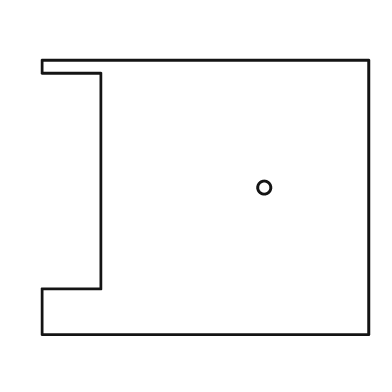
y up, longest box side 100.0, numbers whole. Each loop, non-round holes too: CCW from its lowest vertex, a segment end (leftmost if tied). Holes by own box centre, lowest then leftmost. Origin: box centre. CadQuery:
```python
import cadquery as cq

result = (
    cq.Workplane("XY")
    .moveTo(-50.0, -42.0)
    .lineTo(50.0, -42.0)
    .lineTo(50.0, 42.0)
    .lineTo(-50.0, 42.0)
    .lineTo(-50.0, 38.0)
    .lineTo(-32.0, 38.0)
    .lineTo(-32.0, -28.0)
    .lineTo(-50.0, -28.0)
    .close()
    .moveTo(18.0, 3.0)
    .circle(2.0)
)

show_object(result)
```